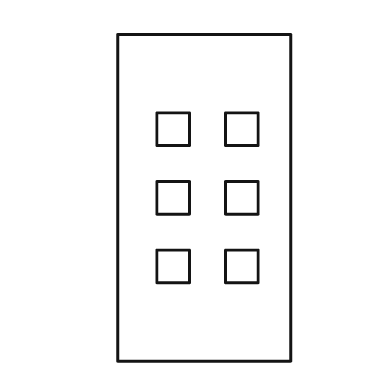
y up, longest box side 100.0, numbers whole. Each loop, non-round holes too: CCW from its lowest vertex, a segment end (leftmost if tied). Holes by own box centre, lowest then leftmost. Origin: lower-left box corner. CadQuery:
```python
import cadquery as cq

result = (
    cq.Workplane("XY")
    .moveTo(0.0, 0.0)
    .lineTo(53.0, 0.0)
    .lineTo(53.0, 100.0)
    .lineTo(0.0, 100.0)
    .close()
    .moveTo(12.0, 24.0)
    .lineTo(22.0, 24.0)
    .lineTo(22.0, 34.0)
    .lineTo(12.0, 34.0)
    .close()
    .moveTo(33.0, 24.0)
    .lineTo(43.0, 24.0)
    .lineTo(43.0, 34.0)
    .lineTo(33.0, 34.0)
    .close()
    .moveTo(12.0, 45.0)
    .lineTo(22.0, 45.0)
    .lineTo(22.0, 55.0)
    .lineTo(12.0, 55.0)
    .close()
    .moveTo(33.0, 45.0)
    .lineTo(43.0, 45.0)
    .lineTo(43.0, 55.0)
    .lineTo(33.0, 55.0)
    .close()
    .moveTo(12.0, 66.0)
    .lineTo(22.0, 66.0)
    .lineTo(22.0, 76.0)
    .lineTo(12.0, 76.0)
    .close()
    .moveTo(33.0, 66.0)
    .lineTo(43.0, 66.0)
    .lineTo(43.0, 76.0)
    .lineTo(33.0, 76.0)
    .close()
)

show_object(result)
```